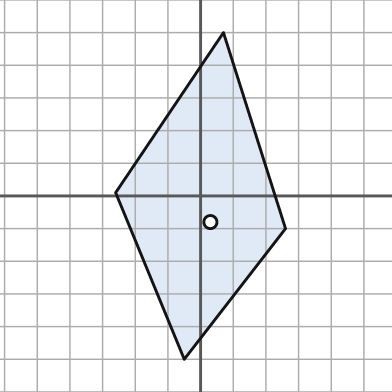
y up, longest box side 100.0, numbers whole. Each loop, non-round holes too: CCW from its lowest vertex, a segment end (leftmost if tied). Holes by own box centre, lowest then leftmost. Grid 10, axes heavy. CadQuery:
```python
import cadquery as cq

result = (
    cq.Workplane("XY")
    .moveTo(-5.0, -50.0)
    .lineTo(26.0, -10.0)
    .lineTo(7.0, 50.0)
    .lineTo(-26.0, 1.0)
    .close()
    .moveTo(3.0, -8.0)
    .circle(2.0)
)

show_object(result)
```